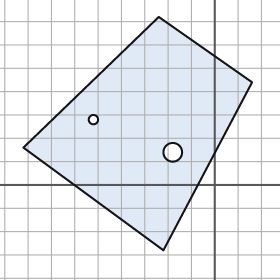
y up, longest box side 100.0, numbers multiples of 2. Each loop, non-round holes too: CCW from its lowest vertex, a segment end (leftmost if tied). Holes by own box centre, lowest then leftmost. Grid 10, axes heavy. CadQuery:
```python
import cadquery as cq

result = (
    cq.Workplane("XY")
    .moveTo(-22.0, -28.0)
    .lineTo(16.0, 44.0)
    .lineTo(-24.0, 72.0)
    .lineTo(-82.0, 16.0)
    .close()
    .moveTo(-18.0, 14.0)
    .circle(4.0)
    .moveTo(-52.0, 28.0)
    .circle(2.0)
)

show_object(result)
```